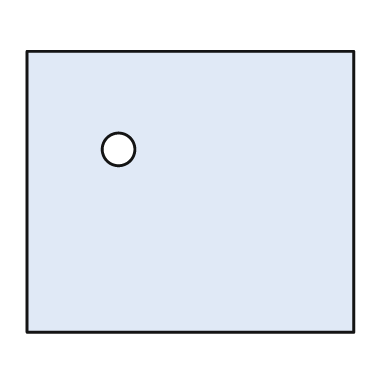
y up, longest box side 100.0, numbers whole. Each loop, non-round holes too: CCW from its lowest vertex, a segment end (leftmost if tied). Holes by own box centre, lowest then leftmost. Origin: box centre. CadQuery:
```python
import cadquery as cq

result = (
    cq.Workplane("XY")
    .moveTo(-50.0, -43.0)
    .lineTo(50.0, -43.0)
    .lineTo(50.0, 43.0)
    .lineTo(-50.0, 43.0)
    .close()
    .moveTo(-22.0, 13.0)
    .circle(5.0)
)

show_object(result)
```